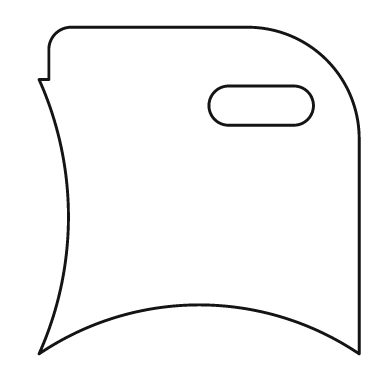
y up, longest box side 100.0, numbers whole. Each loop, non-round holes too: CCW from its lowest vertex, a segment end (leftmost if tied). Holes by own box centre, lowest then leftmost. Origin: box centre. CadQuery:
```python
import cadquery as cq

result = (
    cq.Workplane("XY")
    .moveTo(-49.0, -50.0)
    .threePointArc((0.0, -35.0), (49.0, -50.0))
    .lineTo(49.0, 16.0)
    .threePointArc((39.0, 40.0), (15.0, 50.0))
    .lineTo(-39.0, 50.0)
    .threePointArc((-44.0, 48.0), (-46.0, 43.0))
    .lineTo(-46.0, 34.0)
    .lineTo(-49.0, 34.0)
    .threePointArc((-40.0, -8.0), (-49.0, -50.0))
    .close()
    .moveTo(9.0, 20.0)
    .lineTo(29.0, 20.0)
    .threePointArc((35.0, 26.0), (29.0, 32.0))
    .lineTo(9.0, 32.0)
    .threePointArc((3.0, 26.0), (9.0, 20.0))
    .close()
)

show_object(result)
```